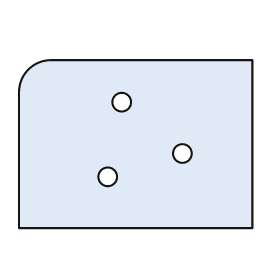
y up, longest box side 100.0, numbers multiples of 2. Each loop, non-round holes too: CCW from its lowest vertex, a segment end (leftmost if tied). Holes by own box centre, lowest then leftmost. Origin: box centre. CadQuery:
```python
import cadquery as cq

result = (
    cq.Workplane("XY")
    .moveTo(-50.0, -36.0)
    .lineTo(50.0, -36.0)
    .lineTo(50.0, 36.0)
    .lineTo(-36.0, 36.0)
    .threePointArc((-46.0, 32.0), (-50.0, 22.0))
    .close()
    .moveTo(-12.0, -14.0)
    .circle(4.0)
    .moveTo(20.0, -4.0)
    .circle(4.0)
    .moveTo(-6.0, 18.0)
    .circle(4.0)
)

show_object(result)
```